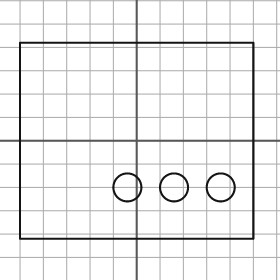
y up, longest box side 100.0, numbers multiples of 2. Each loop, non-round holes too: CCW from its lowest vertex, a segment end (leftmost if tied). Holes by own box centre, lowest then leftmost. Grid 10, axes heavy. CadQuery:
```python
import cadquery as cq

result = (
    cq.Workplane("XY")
    .moveTo(-50.0, -42.0)
    .lineTo(50.0, -42.0)
    .lineTo(50.0, 42.0)
    .lineTo(-50.0, 42.0)
    .close()
    .moveTo(-4.0, -20.0)
    .circle(6.0)
    .moveTo(16.0, -20.0)
    .circle(6.0)
    .moveTo(36.0, -20.0)
    .circle(6.0)
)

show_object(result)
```